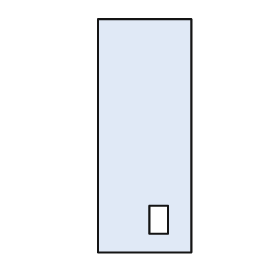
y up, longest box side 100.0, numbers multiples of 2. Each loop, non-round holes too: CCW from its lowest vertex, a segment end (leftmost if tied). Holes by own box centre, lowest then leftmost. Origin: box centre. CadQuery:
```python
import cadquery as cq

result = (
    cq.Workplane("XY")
    .moveTo(-20.0, -50.0)
    .lineTo(20.0, -50.0)
    .lineTo(20.0, 50.0)
    .lineTo(-20.0, 50.0)
    .close()
    .moveTo(2.0, -42.0)
    .lineTo(10.0, -42.0)
    .lineTo(10.0, -30.0)
    .lineTo(2.0, -30.0)
    .close()
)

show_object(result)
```